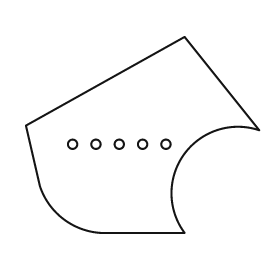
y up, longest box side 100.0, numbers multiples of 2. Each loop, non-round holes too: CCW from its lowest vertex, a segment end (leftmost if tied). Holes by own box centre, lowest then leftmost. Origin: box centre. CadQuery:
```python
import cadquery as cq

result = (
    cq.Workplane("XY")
    .moveTo(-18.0, -42.0)
    .lineTo(18.0, -42.0)
    .threePointArc((18.0, -8.0), (50.0, 2.0))
    .lineTo(18.0, 42.0)
    .lineTo(-50.0, 4.0)
    .lineTo(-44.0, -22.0)
    .threePointArc((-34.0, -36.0), (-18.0, -42.0))
    .close()
    .moveTo(-30.0, -4.0)
    .circle(2.0)
    .moveTo(-20.0, -4.0)
    .circle(2.0)
    .moveTo(-10.0, -4.0)
    .circle(2.0)
    .moveTo(0.0, -4.0)
    .circle(2.0)
    .moveTo(10.0, -4.0)
    .circle(2.0)
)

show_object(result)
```